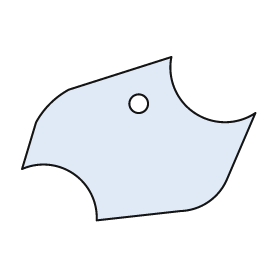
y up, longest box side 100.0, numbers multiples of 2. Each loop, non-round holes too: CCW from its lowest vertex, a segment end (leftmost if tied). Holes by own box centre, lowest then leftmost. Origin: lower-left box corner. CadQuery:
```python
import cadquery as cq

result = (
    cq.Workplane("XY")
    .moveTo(32.0, 0.0)
    .lineTo(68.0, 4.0)
    .threePointArc((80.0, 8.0), (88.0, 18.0))
    .lineTo(100.0, 46.0)
    .threePointArc((74.0, 46.0), (64.0, 70.0))
    .lineTo(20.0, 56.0)
    .threePointArc((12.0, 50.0), (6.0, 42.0))
    .lineTo(0.0, 22.0)
    .threePointArc((22.0, 20.0), (32.0, 0.0))
    .close()
    .moveTo(50.0, 50.0)
    .circle(4.0)
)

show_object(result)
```